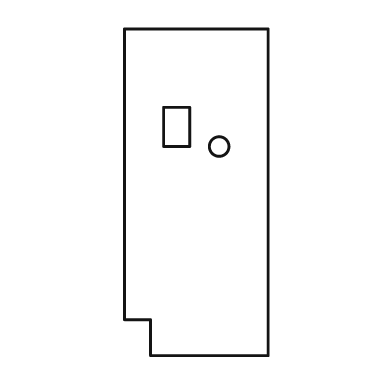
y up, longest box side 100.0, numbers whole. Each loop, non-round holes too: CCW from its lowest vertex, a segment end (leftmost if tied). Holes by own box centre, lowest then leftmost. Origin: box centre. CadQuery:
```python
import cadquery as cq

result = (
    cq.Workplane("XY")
    .moveTo(-14.0, -50.0)
    .lineTo(22.0, -50.0)
    .lineTo(22.0, 50.0)
    .lineTo(-22.0, 50.0)
    .lineTo(-22.0, -39.0)
    .lineTo(-14.0, -39.0)
    .close()
    .moveTo(7.0, 14.0)
    .circle(3.0)
    .moveTo(-10.0, 14.0)
    .lineTo(-2.0, 14.0)
    .lineTo(-2.0, 26.0)
    .lineTo(-10.0, 26.0)
    .close()
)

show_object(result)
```